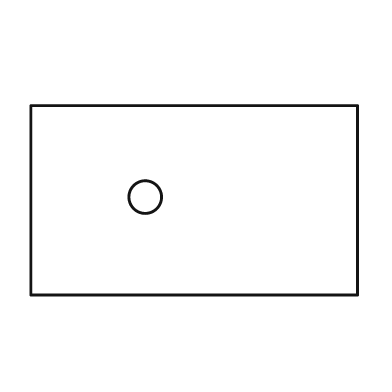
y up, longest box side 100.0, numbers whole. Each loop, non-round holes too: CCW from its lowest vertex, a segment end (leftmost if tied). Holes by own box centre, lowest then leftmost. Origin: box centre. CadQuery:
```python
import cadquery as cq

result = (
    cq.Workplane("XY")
    .moveTo(-50.0, -29.0)
    .lineTo(50.0, -29.0)
    .lineTo(50.0, 29.0)
    .lineTo(-50.0, 29.0)
    .close()
    .moveTo(-15.0, 1.0)
    .circle(5.0)
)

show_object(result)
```